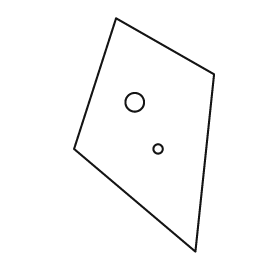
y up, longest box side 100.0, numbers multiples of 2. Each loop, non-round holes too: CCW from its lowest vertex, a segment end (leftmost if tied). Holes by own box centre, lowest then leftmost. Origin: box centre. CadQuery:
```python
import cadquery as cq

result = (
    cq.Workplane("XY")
    .moveTo(22.0, -50.0)
    .lineTo(30.0, 26.0)
    .lineTo(-12.0, 50.0)
    .lineTo(-30.0, -6.0)
    .close()
    .moveTo(6.0, -6.0)
    .circle(2.0)
    .moveTo(-4.0, 14.0)
    .circle(4.0)
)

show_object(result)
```